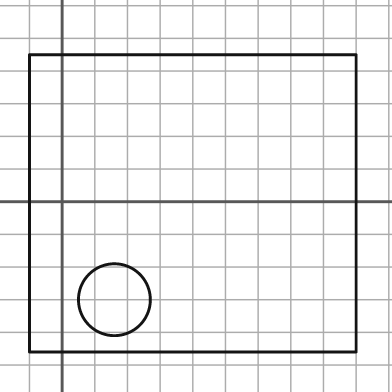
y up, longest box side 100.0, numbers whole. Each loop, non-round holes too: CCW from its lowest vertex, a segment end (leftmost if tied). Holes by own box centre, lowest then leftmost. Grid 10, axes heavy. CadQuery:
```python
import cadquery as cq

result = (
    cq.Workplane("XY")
    .moveTo(-10.0, -46.0)
    .lineTo(90.0, -46.0)
    .lineTo(90.0, 45.0)
    .lineTo(-10.0, 45.0)
    .close()
    .moveTo(16.0, -30.0)
    .circle(11.0)
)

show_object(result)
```